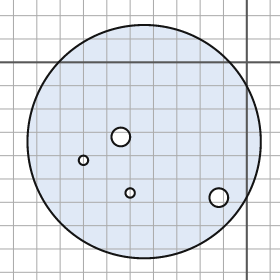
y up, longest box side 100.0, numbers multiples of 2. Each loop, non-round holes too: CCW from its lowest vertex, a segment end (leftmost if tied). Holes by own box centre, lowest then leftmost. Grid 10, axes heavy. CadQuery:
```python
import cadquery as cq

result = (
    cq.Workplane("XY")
    .moveTo(-44.0, -34.0)
    .circle(50.0)
    .moveTo(-12.0, -58.0)
    .circle(4.0)
    .moveTo(-50.0, -56.0)
    .circle(2.0)
    .moveTo(-70.0, -42.0)
    .circle(2.0)
    .moveTo(-54.0, -32.0)
    .circle(4.0)
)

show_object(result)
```